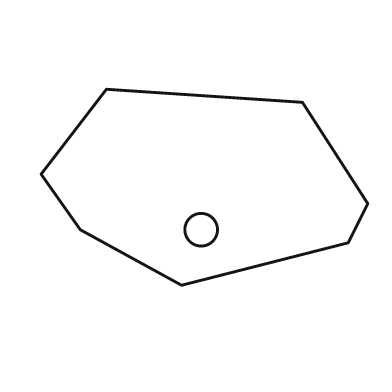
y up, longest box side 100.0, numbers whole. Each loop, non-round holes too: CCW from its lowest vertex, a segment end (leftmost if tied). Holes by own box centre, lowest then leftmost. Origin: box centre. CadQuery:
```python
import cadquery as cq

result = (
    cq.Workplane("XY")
    .moveTo(-7.0, -30.0)
    .lineTo(44.0, -17.0)
    .lineTo(50.0, -5.0)
    .lineTo(30.0, 26.0)
    .lineTo(-30.0, 30.0)
    .lineTo(-50.0, 4.0)
    .lineTo(-38.0, -13.0)
    .close()
    .moveTo(-1.0, -13.0)
    .circle(5.0)
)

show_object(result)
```